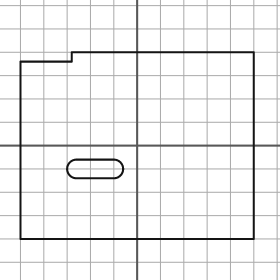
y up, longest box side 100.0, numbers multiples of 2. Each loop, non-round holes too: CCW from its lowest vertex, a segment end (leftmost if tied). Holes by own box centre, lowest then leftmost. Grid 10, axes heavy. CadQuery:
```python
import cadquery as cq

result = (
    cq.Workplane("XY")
    .moveTo(-50.0, -40.0)
    .lineTo(50.0, -40.0)
    .lineTo(50.0, 40.0)
    .lineTo(-28.0, 40.0)
    .lineTo(-28.0, 36.0)
    .lineTo(-50.0, 36.0)
    .close()
    .moveTo(-26.0, -14.0)
    .lineTo(-10.0, -14.0)
    .threePointArc((-6.0, -10.0), (-10.0, -6.0))
    .lineTo(-26.0, -6.0)
    .threePointArc((-30.0, -10.0), (-26.0, -14.0))
    .close()
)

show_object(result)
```